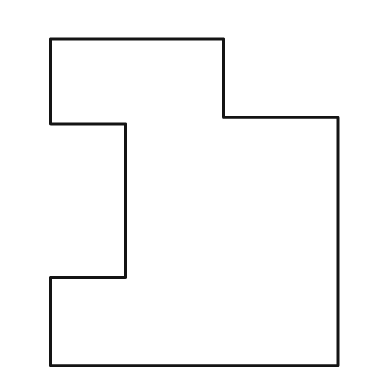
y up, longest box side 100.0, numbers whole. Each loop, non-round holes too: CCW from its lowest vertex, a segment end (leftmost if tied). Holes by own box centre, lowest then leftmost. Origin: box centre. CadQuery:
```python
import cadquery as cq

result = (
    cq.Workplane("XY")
    .moveTo(-44.0, -50.0)
    .lineTo(44.0, -50.0)
    .lineTo(44.0, 26.0)
    .lineTo(9.0, 26.0)
    .lineTo(9.0, 50.0)
    .lineTo(-44.0, 50.0)
    .lineTo(-44.0, 24.0)
    .lineTo(-21.0, 24.0)
    .lineTo(-21.0, -23.0)
    .lineTo(-44.0, -23.0)
    .close()
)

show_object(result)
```